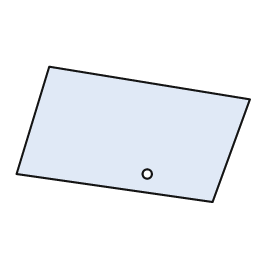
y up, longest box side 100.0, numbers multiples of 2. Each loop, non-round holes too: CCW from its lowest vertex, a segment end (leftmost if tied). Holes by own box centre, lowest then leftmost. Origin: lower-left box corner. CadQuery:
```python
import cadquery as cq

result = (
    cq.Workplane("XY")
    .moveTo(84.0, 0.0)
    .lineTo(100.0, 44.0)
    .lineTo(14.0, 58.0)
    .lineTo(0.0, 12.0)
    .close()
    .moveTo(56.0, 12.0)
    .circle(2.0)
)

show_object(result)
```